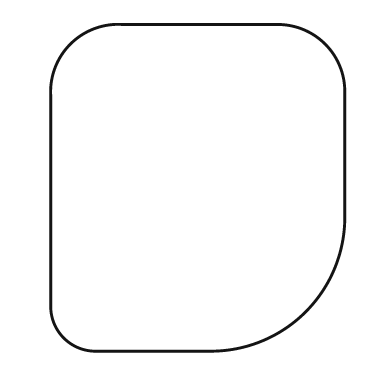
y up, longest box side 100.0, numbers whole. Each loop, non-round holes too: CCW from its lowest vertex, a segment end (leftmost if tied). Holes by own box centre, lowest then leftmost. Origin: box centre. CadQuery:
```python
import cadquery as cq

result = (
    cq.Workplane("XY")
    .moveTo(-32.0, -50.0)
    .lineTo(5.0, -50.0)
    .threePointArc((33.0, -38.0), (45.0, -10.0))
    .lineTo(45.0, 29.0)
    .threePointArc((39.0, 44.0), (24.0, 50.0))
    .lineTo(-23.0, 50.0)
    .threePointArc((-39.0, 44.0), (-45.0, 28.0))
    .lineTo(-45.0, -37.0)
    .threePointArc((-41.0, -46.0), (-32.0, -50.0))
    .close()
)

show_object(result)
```